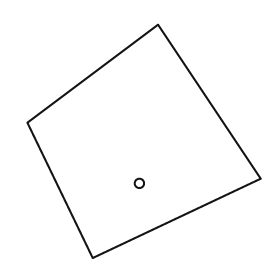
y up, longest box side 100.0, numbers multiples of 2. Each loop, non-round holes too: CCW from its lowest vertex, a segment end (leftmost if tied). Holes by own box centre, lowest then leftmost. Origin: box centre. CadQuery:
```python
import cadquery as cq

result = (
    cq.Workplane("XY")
    .moveTo(-22.0, -50.0)
    .lineTo(50.0, -16.0)
    .lineTo(6.0, 50.0)
    .lineTo(-50.0, 8.0)
    .close()
    .moveTo(-2.0, -18.0)
    .circle(2.0)
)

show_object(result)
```